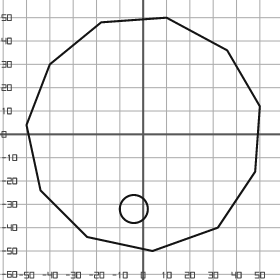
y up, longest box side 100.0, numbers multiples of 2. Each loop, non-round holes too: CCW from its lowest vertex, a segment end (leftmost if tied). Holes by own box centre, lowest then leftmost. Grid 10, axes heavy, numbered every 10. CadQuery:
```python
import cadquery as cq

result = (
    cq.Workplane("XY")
    .moveTo(4.0, -50.0)
    .lineTo(32.0, -40.0)
    .lineTo(48.0, -16.0)
    .lineTo(50.0, 12.0)
    .lineTo(36.0, 36.0)
    .lineTo(10.0, 50.0)
    .lineTo(-18.0, 48.0)
    .lineTo(-40.0, 30.0)
    .lineTo(-50.0, 4.0)
    .lineTo(-44.0, -24.0)
    .lineTo(-24.0, -44.0)
    .close()
    .moveTo(-4.0, -32.0)
    .circle(6.0)
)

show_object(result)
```